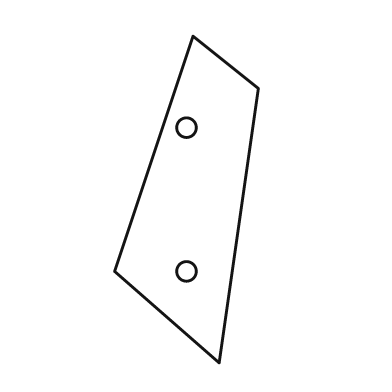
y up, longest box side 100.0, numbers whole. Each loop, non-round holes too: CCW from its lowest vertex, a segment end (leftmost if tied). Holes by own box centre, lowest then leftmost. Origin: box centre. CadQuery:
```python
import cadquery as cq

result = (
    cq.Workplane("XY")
    .moveTo(10.0, -50.0)
    .lineTo(22.0, 34.0)
    .lineTo(2.0, 50.0)
    .lineTo(-22.0, -22.0)
    .close()
    .moveTo(0.0, -22.0)
    .circle(3.0)
    .moveTo(0.0, 22.0)
    .circle(3.0)
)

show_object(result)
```